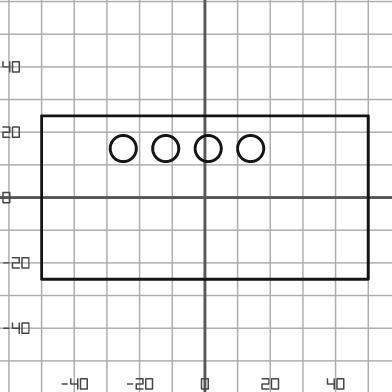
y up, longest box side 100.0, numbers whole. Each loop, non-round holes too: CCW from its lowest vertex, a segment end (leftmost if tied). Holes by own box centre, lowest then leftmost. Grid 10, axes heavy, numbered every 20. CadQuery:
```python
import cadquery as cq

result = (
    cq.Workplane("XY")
    .moveTo(-50.0, -25.0)
    .lineTo(50.0, -25.0)
    .lineTo(50.0, 25.0)
    .lineTo(-50.0, 25.0)
    .close()
    .moveTo(-25.0, 15.0)
    .circle(4.0)
    .moveTo(-12.0, 15.0)
    .circle(4.0)
    .moveTo(1.0, 15.0)
    .circle(4.0)
    .moveTo(14.0, 15.0)
    .circle(4.0)
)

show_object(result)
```